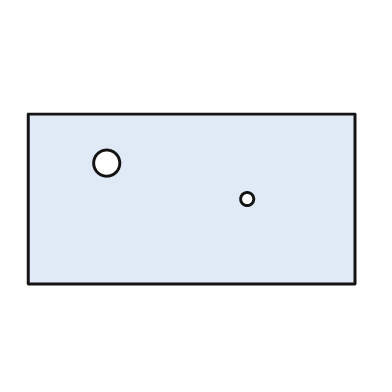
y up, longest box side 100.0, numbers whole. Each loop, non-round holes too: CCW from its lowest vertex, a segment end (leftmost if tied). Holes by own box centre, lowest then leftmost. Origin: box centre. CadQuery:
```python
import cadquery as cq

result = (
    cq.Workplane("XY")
    .moveTo(-50.0, -26.0)
    .lineTo(50.0, -26.0)
    .lineTo(50.0, 26.0)
    .lineTo(-50.0, 26.0)
    .close()
    .moveTo(17.0, 0.0)
    .circle(2.0)
    .moveTo(-26.0, 11.0)
    .circle(4.0)
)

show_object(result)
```